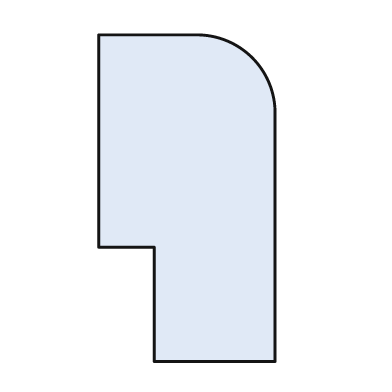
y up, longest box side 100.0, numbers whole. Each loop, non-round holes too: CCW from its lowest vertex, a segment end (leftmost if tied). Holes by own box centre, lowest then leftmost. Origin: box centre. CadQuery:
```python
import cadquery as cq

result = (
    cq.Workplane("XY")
    .moveTo(-10.0, -50.0)
    .lineTo(27.0, -50.0)
    .lineTo(27.0, 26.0)
    .threePointArc((20.0, 43.0), (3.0, 50.0))
    .lineTo(-27.0, 50.0)
    .lineTo(-27.0, -15.0)
    .lineTo(-10.0, -15.0)
    .close()
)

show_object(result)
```